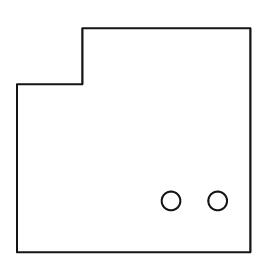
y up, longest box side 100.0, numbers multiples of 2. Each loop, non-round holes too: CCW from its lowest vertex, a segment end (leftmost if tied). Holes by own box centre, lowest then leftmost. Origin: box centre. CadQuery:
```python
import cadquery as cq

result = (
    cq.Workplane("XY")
    .moveTo(-50.0, -48.0)
    .lineTo(50.0, -48.0)
    .lineTo(50.0, 48.0)
    .lineTo(-22.0, 48.0)
    .lineTo(-22.0, 24.0)
    .lineTo(-50.0, 24.0)
    .close()
    .moveTo(16.0, -26.0)
    .circle(4.0)
    .moveTo(36.0, -26.0)
    .circle(4.0)
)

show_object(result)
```